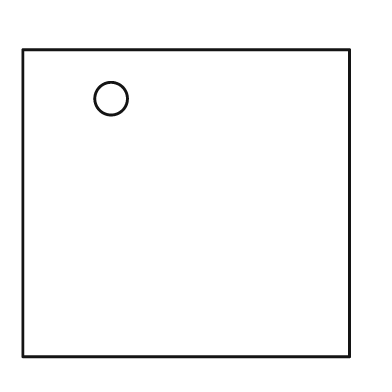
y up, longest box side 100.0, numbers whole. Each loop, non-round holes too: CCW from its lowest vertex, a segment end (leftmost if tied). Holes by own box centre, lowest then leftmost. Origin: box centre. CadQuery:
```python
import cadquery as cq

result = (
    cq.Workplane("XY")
    .moveTo(-50.0, -47.0)
    .lineTo(50.0, -47.0)
    .lineTo(50.0, 47.0)
    .lineTo(-50.0, 47.0)
    .close()
    .moveTo(-23.0, 32.0)
    .circle(5.0)
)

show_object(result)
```